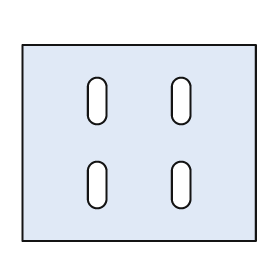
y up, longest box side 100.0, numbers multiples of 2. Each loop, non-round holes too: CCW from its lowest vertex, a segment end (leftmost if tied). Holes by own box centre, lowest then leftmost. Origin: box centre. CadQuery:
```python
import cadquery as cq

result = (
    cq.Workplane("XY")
    .moveTo(-50.0, -42.0)
    .lineTo(50.0, -42.0)
    .lineTo(50.0, 42.0)
    .lineTo(-50.0, 42.0)
    .close()
    .moveTo(-22.0, -24.0)
    .threePointArc((-18.0, -28.0), (-14.0, -24.0))
    .lineTo(-14.0, -12.0)
    .threePointArc((-18.0, -8.0), (-22.0, -12.0))
    .close()
    .moveTo(14.0, -24.0)
    .threePointArc((18.0, -28.0), (22.0, -24.0))
    .lineTo(22.0, -12.0)
    .threePointArc((18.0, -8.0), (14.0, -12.0))
    .close()
    .moveTo(-22.0, 12.0)
    .threePointArc((-18.0, 8.0), (-14.0, 12.0))
    .lineTo(-14.0, 24.0)
    .threePointArc((-18.0, 28.0), (-22.0, 24.0))
    .close()
    .moveTo(14.0, 12.0)
    .threePointArc((18.0, 8.0), (22.0, 12.0))
    .lineTo(22.0, 24.0)
    .threePointArc((18.0, 28.0), (14.0, 24.0))
    .close()
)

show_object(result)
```